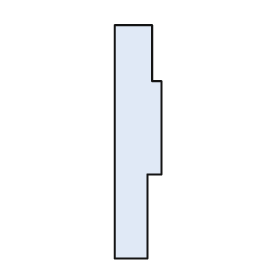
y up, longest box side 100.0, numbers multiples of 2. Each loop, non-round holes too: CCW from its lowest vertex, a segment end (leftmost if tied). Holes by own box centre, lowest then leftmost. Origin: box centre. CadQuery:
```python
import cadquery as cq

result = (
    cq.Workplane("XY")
    .moveTo(-10.0, -50.0)
    .lineTo(4.0, -50.0)
    .lineTo(4.0, -14.0)
    .lineTo(10.0, -14.0)
    .lineTo(10.0, 26.0)
    .lineTo(6.0, 26.0)
    .lineTo(6.0, 50.0)
    .lineTo(-10.0, 50.0)
    .close()
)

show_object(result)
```